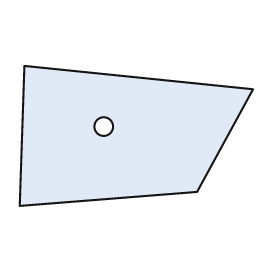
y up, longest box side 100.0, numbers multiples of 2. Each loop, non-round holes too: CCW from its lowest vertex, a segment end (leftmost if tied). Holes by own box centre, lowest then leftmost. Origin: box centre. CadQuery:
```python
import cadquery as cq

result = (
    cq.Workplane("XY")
    .moveTo(-50.0, -30.0)
    .lineTo(26.0, -24.0)
    .lineTo(50.0, 20.0)
    .lineTo(-48.0, 30.0)
    .close()
    .moveTo(-14.0, 4.0)
    .circle(4.0)
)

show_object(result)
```